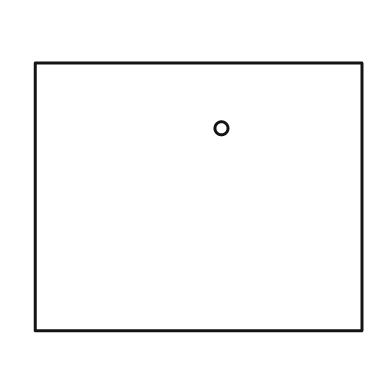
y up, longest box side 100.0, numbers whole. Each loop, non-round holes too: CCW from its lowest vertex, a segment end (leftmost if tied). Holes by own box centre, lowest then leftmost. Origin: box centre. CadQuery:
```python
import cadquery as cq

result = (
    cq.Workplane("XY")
    .moveTo(-50.0, -41.0)
    .lineTo(50.0, -41.0)
    .lineTo(50.0, 41.0)
    .lineTo(-50.0, 41.0)
    .close()
    .moveTo(7.0, 21.0)
    .circle(2.0)
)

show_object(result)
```